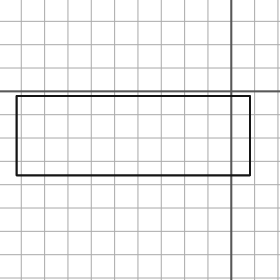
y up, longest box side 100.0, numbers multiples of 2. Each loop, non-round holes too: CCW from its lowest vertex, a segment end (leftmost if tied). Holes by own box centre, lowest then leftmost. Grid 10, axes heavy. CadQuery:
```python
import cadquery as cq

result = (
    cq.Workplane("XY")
    .moveTo(-92.0, -36.0)
    .lineTo(8.0, -36.0)
    .lineTo(8.0, -2.0)
    .lineTo(-92.0, -2.0)
    .close()
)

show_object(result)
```